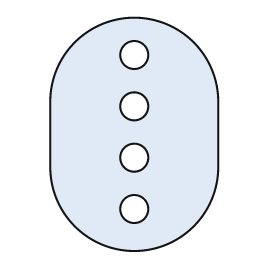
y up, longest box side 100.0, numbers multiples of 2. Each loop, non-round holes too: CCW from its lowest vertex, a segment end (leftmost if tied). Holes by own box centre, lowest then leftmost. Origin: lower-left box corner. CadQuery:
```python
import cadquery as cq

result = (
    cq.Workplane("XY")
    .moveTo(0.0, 36.0)
    .threePointArc((36.0, 0.0), (72.0, 36.0))
    .lineTo(72.0, 64.0)
    .threePointArc((36.0, 100.0), (0.0, 64.0))
    .close()
    .moveTo(36.0, 18.0)
    .circle(6.0)
    .moveTo(36.0, 40.0)
    .circle(6.0)
    .moveTo(36.0, 62.0)
    .circle(6.0)
    .moveTo(36.0, 84.0)
    .circle(6.0)
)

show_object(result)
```